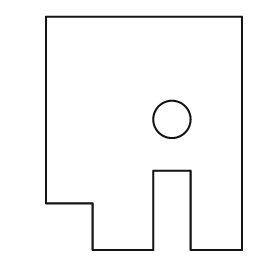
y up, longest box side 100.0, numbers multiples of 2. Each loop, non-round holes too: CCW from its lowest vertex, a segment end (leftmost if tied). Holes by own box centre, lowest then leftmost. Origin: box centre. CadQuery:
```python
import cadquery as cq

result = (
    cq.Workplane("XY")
    .moveTo(-22.0, -50.0)
    .lineTo(4.0, -50.0)
    .lineTo(4.0, -16.0)
    .lineTo(20.0, -16.0)
    .lineTo(20.0, -50.0)
    .lineTo(42.0, -50.0)
    .lineTo(42.0, 50.0)
    .lineTo(-42.0, 50.0)
    .lineTo(-42.0, -30.0)
    .lineTo(-22.0, -30.0)
    .close()
    .moveTo(12.0, 6.0)
    .circle(8.0)
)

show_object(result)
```